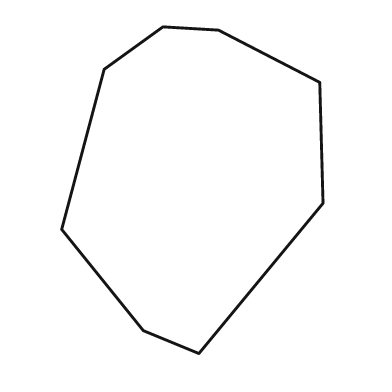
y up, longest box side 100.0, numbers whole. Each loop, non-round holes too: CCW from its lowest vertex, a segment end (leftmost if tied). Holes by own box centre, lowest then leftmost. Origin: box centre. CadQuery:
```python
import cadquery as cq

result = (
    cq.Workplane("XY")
    .moveTo(2.0, -50.0)
    .lineTo(40.0, -4.0)
    .lineTo(39.0, 33.0)
    .lineTo(8.0, 49.0)
    .lineTo(-9.0, 50.0)
    .lineTo(-27.0, 37.0)
    .lineTo(-40.0, -12.0)
    .lineTo(-15.0, -43.0)
    .close()
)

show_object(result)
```